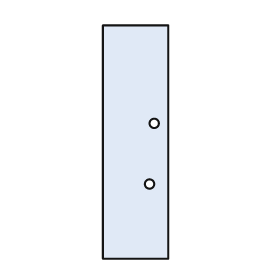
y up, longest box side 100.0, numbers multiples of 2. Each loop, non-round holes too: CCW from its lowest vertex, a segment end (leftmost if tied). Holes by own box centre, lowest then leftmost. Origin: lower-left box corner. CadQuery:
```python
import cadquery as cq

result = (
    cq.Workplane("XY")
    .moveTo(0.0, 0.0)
    .lineTo(28.0, 0.0)
    .lineTo(28.0, 100.0)
    .lineTo(0.0, 100.0)
    .close()
    .moveTo(20.0, 32.0)
    .circle(2.0)
    .moveTo(22.0, 58.0)
    .circle(2.0)
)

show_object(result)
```